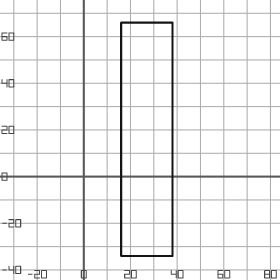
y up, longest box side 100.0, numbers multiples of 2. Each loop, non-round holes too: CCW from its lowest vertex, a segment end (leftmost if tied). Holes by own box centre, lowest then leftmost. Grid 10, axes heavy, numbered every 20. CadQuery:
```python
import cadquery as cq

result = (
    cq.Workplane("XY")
    .moveTo(16.0, -34.0)
    .lineTo(38.0, -34.0)
    .lineTo(38.0, 66.0)
    .lineTo(16.0, 66.0)
    .close()
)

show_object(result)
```